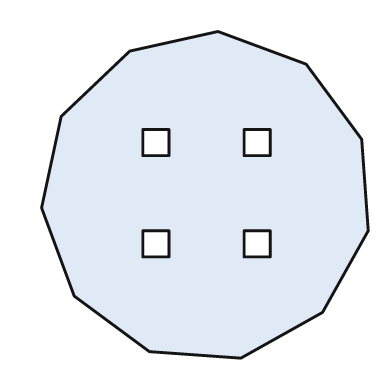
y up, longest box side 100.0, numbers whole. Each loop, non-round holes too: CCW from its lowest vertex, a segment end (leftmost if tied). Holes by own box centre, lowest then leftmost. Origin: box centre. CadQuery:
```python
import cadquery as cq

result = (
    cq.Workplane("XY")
    .moveTo(11.0, -50.0)
    .lineTo(36.0, -36.0)
    .lineTo(50.0, -11.0)
    .lineTo(48.0, 17.0)
    .lineTo(31.0, 40.0)
    .lineTo(4.0, 50.0)
    .lineTo(-23.0, 44.0)
    .lineTo(-44.0, 24.0)
    .lineTo(-50.0, -4.0)
    .lineTo(-40.0, -31.0)
    .lineTo(-17.0, -48.0)
    .close()
    .moveTo(-19.0, -19.0)
    .lineTo(-11.0, -19.0)
    .lineTo(-11.0, -11.0)
    .lineTo(-19.0, -11.0)
    .close()
    .moveTo(12.0, -19.0)
    .lineTo(20.0, -19.0)
    .lineTo(20.0, -11.0)
    .lineTo(12.0, -11.0)
    .close()
    .moveTo(-19.0, 12.0)
    .lineTo(-11.0, 12.0)
    .lineTo(-11.0, 20.0)
    .lineTo(-19.0, 20.0)
    .close()
    .moveTo(12.0, 12.0)
    .lineTo(20.0, 12.0)
    .lineTo(20.0, 20.0)
    .lineTo(12.0, 20.0)
    .close()
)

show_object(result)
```